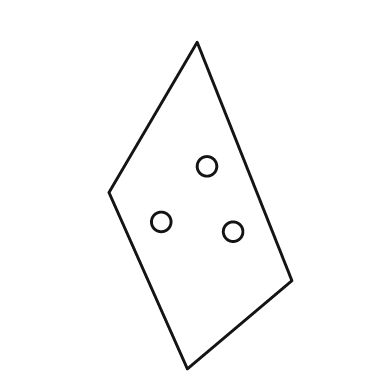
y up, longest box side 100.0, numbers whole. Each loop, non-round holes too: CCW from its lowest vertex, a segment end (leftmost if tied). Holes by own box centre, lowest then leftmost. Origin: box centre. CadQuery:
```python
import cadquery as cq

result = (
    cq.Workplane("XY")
    .moveTo(-4.0, -50.0)
    .lineTo(28.0, -23.0)
    .lineTo(-1.0, 50.0)
    .lineTo(-28.0, 4.0)
    .close()
    .moveTo(10.0, -8.0)
    .circle(3.0)
    .moveTo(-12.0, -5.0)
    .circle(3.0)
    .moveTo(2.0, 12.0)
    .circle(3.0)
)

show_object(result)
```